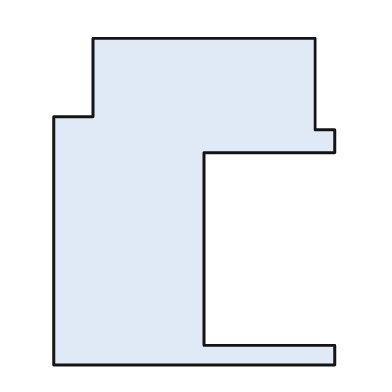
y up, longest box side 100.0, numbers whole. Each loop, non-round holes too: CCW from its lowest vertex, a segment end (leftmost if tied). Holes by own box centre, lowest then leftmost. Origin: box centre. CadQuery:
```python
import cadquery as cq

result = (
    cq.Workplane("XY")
    .moveTo(-43.0, -50.0)
    .lineTo(43.0, -50.0)
    .lineTo(43.0, -44.0)
    .lineTo(3.0, -44.0)
    .lineTo(3.0, 15.0)
    .lineTo(43.0, 15.0)
    .lineTo(43.0, 22.0)
    .lineTo(37.0, 22.0)
    .lineTo(37.0, 50.0)
    .lineTo(-31.0, 50.0)
    .lineTo(-31.0, 26.0)
    .lineTo(-43.0, 26.0)
    .close()
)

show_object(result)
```